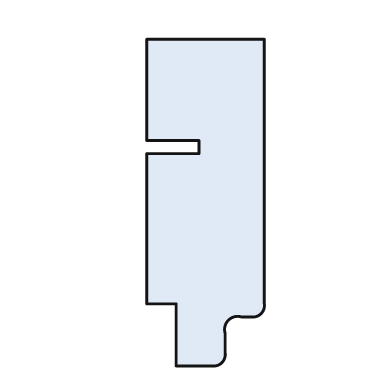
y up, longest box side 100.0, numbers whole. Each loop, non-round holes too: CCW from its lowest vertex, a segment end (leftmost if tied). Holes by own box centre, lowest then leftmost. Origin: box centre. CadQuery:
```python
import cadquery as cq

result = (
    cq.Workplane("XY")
    .moveTo(-9.0, -50.0)
    .lineTo(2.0, -50.0)
    .threePointArc((5.0, -49.0), (6.0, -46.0))
    .lineTo(6.0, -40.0)
    .threePointArc((7.0, -36.0), (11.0, -35.0))
    .lineTo(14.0, -35.0)
    .threePointArc((17.0, -34.0), (18.0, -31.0))
    .lineTo(18.0, 50.0)
    .lineTo(-18.0, 50.0)
    .lineTo(-18.0, 19.0)
    .lineTo(-2.0, 19.0)
    .lineTo(-2.0, 15.0)
    .lineTo(-18.0, 15.0)
    .lineTo(-18.0, -31.0)
    .lineTo(-9.0, -31.0)
    .close()
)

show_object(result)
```